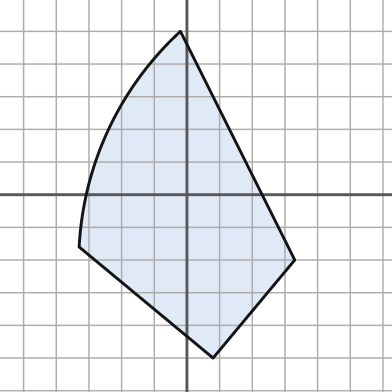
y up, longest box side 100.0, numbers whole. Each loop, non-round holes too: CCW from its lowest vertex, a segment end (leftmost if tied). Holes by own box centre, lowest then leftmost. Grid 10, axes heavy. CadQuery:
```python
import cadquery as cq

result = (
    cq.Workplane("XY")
    .moveTo(8.0, -50.0)
    .lineTo(33.0, -20.0)
    .lineTo(-2.0, 50.0)
    .threePointArc((-24.0, 20.0), (-33.0, -16.0))
    .close()
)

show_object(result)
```